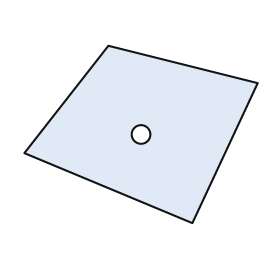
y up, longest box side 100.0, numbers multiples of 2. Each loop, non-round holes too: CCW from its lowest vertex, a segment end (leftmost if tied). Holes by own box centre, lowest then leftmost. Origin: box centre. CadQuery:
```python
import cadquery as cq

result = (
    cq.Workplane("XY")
    .moveTo(22.0, -38.0)
    .lineTo(50.0, 22.0)
    .lineTo(-14.0, 38.0)
    .lineTo(-50.0, -8.0)
    .close()
    .moveTo(0.0, 0.0)
    .circle(4.0)
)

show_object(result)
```